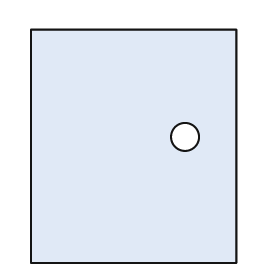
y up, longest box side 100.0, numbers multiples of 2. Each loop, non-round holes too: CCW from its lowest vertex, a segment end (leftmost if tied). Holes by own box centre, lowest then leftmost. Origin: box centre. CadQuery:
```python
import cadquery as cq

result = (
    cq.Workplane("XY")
    .moveTo(-44.0, -50.0)
    .lineTo(44.0, -50.0)
    .lineTo(44.0, 50.0)
    .lineTo(-44.0, 50.0)
    .close()
    .moveTo(22.0, 4.0)
    .circle(6.0)
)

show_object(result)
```